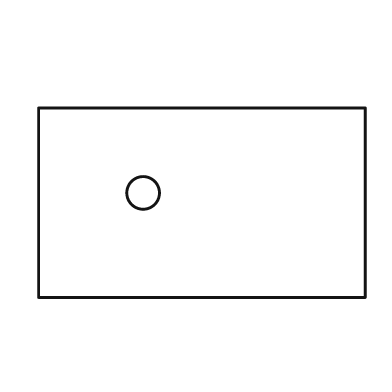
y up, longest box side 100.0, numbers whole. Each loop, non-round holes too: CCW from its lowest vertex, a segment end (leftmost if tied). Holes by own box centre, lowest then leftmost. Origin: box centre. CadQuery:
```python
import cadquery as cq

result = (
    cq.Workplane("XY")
    .moveTo(-50.0, -29.0)
    .lineTo(50.0, -29.0)
    .lineTo(50.0, 29.0)
    .lineTo(-50.0, 29.0)
    .close()
    .moveTo(-18.0, 3.0)
    .circle(5.0)
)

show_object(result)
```